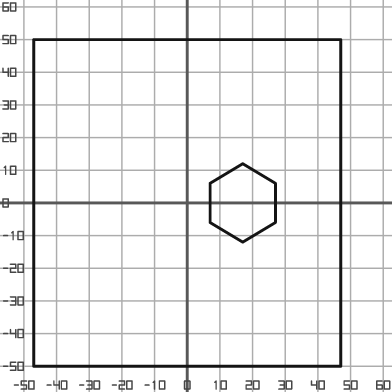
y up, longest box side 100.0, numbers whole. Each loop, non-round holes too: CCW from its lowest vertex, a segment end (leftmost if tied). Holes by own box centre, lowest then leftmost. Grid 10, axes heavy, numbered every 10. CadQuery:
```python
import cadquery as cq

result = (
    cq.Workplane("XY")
    .moveTo(-47.0, -50.0)
    .lineTo(47.0, -50.0)
    .lineTo(47.0, 50.0)
    .lineTo(-47.0, 50.0)
    .close()
    .moveTo(17.0, -12.0)
    .lineTo(27.0, -6.0)
    .lineTo(27.0, 6.0)
    .lineTo(17.0, 12.0)
    .lineTo(7.0, 6.0)
    .lineTo(7.0, -6.0)
    .close()
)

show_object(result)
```